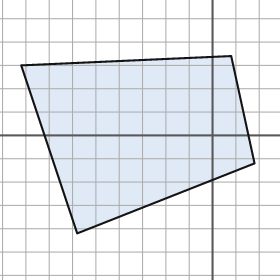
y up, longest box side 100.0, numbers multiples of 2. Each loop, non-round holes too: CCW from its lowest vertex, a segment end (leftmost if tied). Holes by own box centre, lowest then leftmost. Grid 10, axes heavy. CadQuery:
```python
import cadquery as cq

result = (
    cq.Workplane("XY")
    .moveTo(-58.0, -42.0)
    .lineTo(18.0, -12.0)
    .lineTo(8.0, 34.0)
    .lineTo(-82.0, 30.0)
    .close()
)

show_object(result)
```